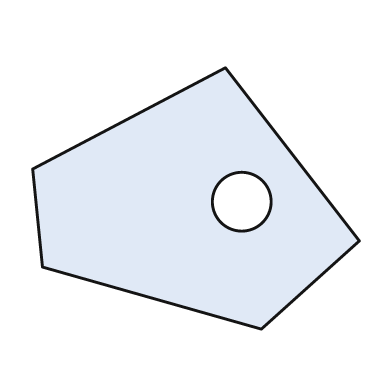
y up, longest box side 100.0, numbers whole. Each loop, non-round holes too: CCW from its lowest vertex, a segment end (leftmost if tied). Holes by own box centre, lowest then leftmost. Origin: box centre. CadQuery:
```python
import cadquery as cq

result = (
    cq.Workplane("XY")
    .moveTo(20.0, -40.0)
    .lineTo(50.0, -13.0)
    .lineTo(9.0, 40.0)
    .lineTo(-50.0, 9.0)
    .lineTo(-47.0, -21.0)
    .close()
    .moveTo(14.0, -1.0)
    .circle(9.0)
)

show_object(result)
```